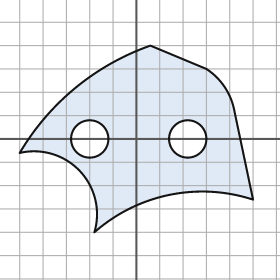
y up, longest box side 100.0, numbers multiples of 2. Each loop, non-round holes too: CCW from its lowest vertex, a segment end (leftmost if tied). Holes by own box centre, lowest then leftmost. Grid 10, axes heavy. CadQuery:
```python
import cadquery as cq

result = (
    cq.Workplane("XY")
    .moveTo(-18.0, -40.0)
    .threePointArc((14.0, -24.0), (50.0, -26.0))
    .lineTo(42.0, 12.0)
    .threePointArc((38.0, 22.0), (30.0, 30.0))
    .lineTo(6.0, 40.0)
    .threePointArc((-26.0, 22.0), (-50.0, -6.0))
    .threePointArc((-24.0, -14.0), (-18.0, -40.0))
    .close()
    .moveTo(-20.0, 0.0)
    .circle(8.0)
    .moveTo(22.0, 0.0)
    .circle(8.0)
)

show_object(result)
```